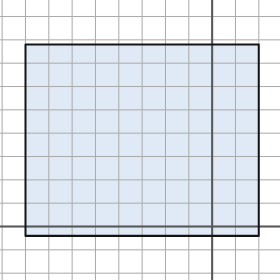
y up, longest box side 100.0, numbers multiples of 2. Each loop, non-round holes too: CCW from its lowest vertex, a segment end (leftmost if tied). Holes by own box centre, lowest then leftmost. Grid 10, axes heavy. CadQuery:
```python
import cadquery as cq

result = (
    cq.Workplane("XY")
    .moveTo(-80.0, -4.0)
    .lineTo(20.0, -4.0)
    .lineTo(20.0, 78.0)
    .lineTo(-80.0, 78.0)
    .close()
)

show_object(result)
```